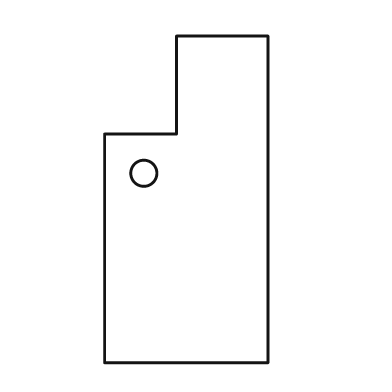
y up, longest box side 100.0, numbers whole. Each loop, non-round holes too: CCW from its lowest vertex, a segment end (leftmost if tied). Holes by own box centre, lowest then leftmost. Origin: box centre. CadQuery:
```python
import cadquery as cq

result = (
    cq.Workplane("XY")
    .moveTo(-25.0, -50.0)
    .lineTo(25.0, -50.0)
    .lineTo(25.0, 50.0)
    .lineTo(-3.0, 50.0)
    .lineTo(-3.0, 20.0)
    .lineTo(-25.0, 20.0)
    .close()
    .moveTo(-13.0, 8.0)
    .circle(4.0)
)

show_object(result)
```